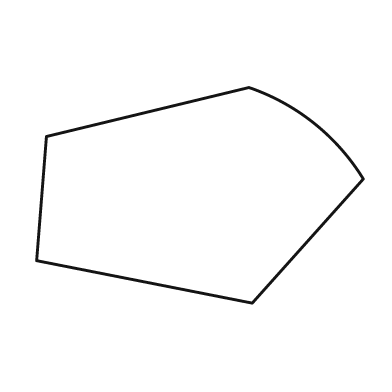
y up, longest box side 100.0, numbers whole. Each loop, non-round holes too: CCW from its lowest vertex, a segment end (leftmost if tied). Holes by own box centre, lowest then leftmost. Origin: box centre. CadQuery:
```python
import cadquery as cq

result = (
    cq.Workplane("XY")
    .moveTo(16.0, -33.0)
    .lineTo(50.0, 5.0)
    .threePointArc((35.0, 22.0), (15.0, 33.0))
    .lineTo(-47.0, 18.0)
    .lineTo(-50.0, -20.0)
    .close()
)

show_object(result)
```